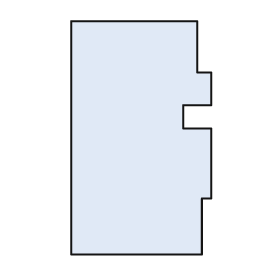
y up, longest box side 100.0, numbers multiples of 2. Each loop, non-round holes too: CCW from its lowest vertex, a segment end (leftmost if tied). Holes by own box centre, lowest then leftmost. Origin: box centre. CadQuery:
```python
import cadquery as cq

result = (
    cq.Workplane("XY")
    .moveTo(-30.0, -50.0)
    .lineTo(26.0, -50.0)
    .lineTo(26.0, -26.0)
    .lineTo(30.0, -26.0)
    .lineTo(30.0, 4.0)
    .lineTo(18.0, 4.0)
    .lineTo(18.0, 14.0)
    .lineTo(30.0, 14.0)
    .lineTo(30.0, 28.0)
    .lineTo(24.0, 28.0)
    .lineTo(24.0, 50.0)
    .lineTo(-30.0, 50.0)
    .close()
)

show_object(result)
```